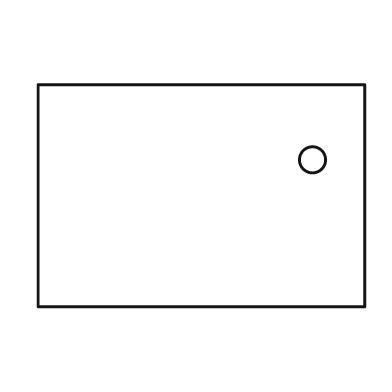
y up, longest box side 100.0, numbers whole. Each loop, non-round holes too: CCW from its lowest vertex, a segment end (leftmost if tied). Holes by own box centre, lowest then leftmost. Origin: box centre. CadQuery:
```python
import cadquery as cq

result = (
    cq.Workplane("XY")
    .moveTo(-50.0, -34.0)
    .lineTo(50.0, -34.0)
    .lineTo(50.0, 34.0)
    .lineTo(-50.0, 34.0)
    .close()
    .moveTo(34.0, 11.0)
    .circle(4.0)
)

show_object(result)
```